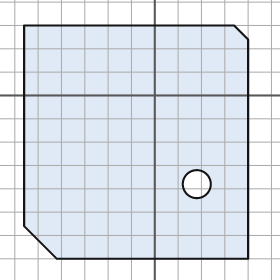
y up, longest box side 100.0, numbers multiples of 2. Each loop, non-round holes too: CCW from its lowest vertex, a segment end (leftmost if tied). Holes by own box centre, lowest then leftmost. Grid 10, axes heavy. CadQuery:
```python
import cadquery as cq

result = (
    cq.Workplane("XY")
    .moveTo(-42.0, -70.0)
    .lineTo(40.0, -70.0)
    .lineTo(40.0, 24.0)
    .lineTo(34.0, 30.0)
    .lineTo(-56.0, 30.0)
    .lineTo(-56.0, -56.0)
    .close()
    .moveTo(18.0, -38.0)
    .circle(6.0)
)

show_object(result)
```